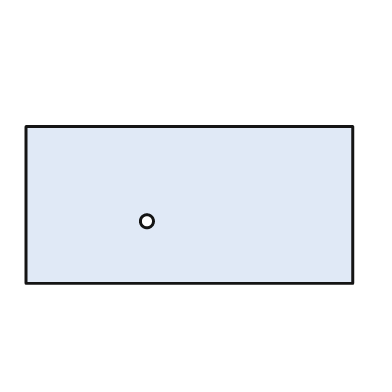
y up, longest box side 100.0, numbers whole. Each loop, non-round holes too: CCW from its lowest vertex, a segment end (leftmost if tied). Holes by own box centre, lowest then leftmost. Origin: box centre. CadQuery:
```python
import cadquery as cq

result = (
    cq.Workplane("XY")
    .moveTo(-50.0, -24.0)
    .lineTo(50.0, -24.0)
    .lineTo(50.0, 24.0)
    .lineTo(-50.0, 24.0)
    .close()
    .moveTo(-13.0, -5.0)
    .circle(2.0)
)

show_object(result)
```